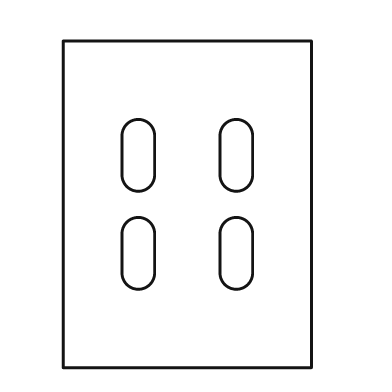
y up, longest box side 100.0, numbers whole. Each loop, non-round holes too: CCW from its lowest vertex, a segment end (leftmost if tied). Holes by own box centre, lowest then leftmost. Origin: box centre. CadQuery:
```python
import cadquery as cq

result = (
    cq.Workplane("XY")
    .moveTo(-38.0, -50.0)
    .lineTo(38.0, -50.0)
    .lineTo(38.0, 50.0)
    .lineTo(-38.0, 50.0)
    .close()
    .moveTo(-20.0, -21.0)
    .threePointArc((-15.0, -26.0), (-10.0, -21.0))
    .lineTo(-10.0, -9.0)
    .threePointArc((-15.0, -4.0), (-20.0, -9.0))
    .close()
    .moveTo(10.0, -21.0)
    .threePointArc((15.0, -26.0), (20.0, -21.0))
    .lineTo(20.0, -9.0)
    .threePointArc((15.0, -4.0), (10.0, -9.0))
    .close()
    .moveTo(-20.0, 9.0)
    .threePointArc((-15.0, 4.0), (-10.0, 9.0))
    .lineTo(-10.0, 21.0)
    .threePointArc((-15.0, 26.0), (-20.0, 21.0))
    .close()
    .moveTo(10.0, 9.0)
    .threePointArc((15.0, 4.0), (20.0, 9.0))
    .lineTo(20.0, 21.0)
    .threePointArc((15.0, 26.0), (10.0, 21.0))
    .close()
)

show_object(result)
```